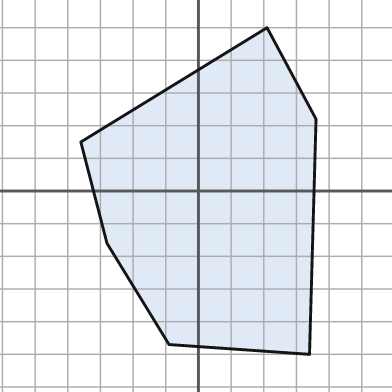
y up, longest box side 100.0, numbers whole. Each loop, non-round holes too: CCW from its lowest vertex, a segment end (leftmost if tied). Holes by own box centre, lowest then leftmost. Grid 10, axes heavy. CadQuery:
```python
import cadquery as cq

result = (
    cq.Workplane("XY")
    .moveTo(34.0, -50.0)
    .lineTo(36.0, 22.0)
    .lineTo(21.0, 50.0)
    .lineTo(-36.0, 15.0)
    .lineTo(-28.0, -16.0)
    .lineTo(-9.0, -47.0)
    .close()
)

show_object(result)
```